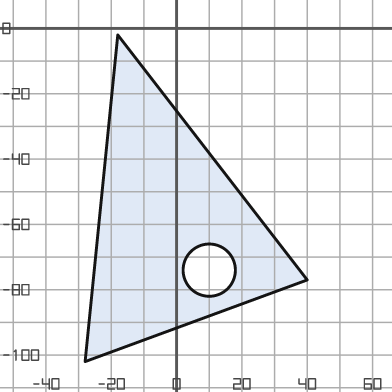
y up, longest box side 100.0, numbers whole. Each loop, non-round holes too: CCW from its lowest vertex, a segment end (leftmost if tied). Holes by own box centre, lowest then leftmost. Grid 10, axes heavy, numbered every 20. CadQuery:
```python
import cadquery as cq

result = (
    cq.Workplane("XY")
    .moveTo(-28.0, -102.0)
    .lineTo(40.0, -77.0)
    .lineTo(-18.0, -2.0)
    .close()
    .moveTo(10.0, -74.0)
    .circle(8.0)
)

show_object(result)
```